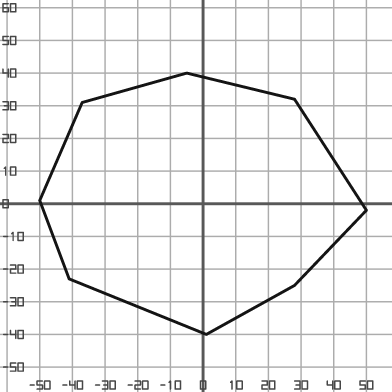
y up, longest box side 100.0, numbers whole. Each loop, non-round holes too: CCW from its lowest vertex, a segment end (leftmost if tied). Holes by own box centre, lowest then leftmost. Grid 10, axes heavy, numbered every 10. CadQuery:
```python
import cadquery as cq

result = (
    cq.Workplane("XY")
    .moveTo(1.0, -40.0)
    .lineTo(28.0, -25.0)
    .lineTo(50.0, -2.0)
    .lineTo(28.0, 32.0)
    .lineTo(-5.0, 40.0)
    .lineTo(-37.0, 31.0)
    .lineTo(-50.0, 1.0)
    .lineTo(-41.0, -23.0)
    .close()
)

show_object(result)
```